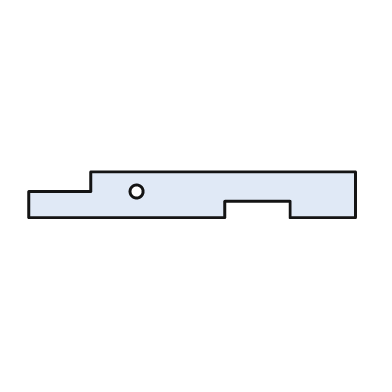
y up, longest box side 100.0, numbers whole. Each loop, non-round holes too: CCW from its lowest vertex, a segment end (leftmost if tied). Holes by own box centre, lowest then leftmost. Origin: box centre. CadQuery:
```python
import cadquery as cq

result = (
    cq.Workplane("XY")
    .moveTo(-50.0, -7.0)
    .lineTo(10.0, -7.0)
    .lineTo(10.0, -2.0)
    .lineTo(30.0, -2.0)
    .lineTo(30.0, -7.0)
    .lineTo(50.0, -7.0)
    .lineTo(50.0, 7.0)
    .lineTo(-31.0, 7.0)
    .lineTo(-31.0, 1.0)
    .lineTo(-50.0, 1.0)
    .close()
    .moveTo(-17.0, 1.0)
    .circle(2.0)
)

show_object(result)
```